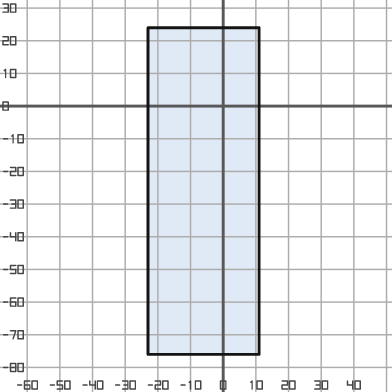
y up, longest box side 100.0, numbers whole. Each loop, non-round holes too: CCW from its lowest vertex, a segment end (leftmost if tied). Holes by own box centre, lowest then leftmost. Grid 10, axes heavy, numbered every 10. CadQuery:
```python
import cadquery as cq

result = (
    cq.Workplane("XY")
    .moveTo(-23.0, -76.0)
    .lineTo(11.0, -76.0)
    .lineTo(11.0, 24.0)
    .lineTo(-23.0, 24.0)
    .close()
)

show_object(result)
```